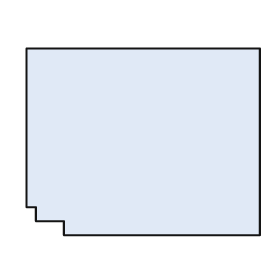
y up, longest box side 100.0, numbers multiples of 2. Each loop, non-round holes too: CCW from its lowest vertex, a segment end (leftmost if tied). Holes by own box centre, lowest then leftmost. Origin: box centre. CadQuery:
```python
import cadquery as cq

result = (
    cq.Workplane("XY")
    .moveTo(-34.0, -40.0)
    .lineTo(50.0, -40.0)
    .lineTo(50.0, 40.0)
    .lineTo(-50.0, 40.0)
    .lineTo(-50.0, -28.0)
    .lineTo(-46.0, -28.0)
    .lineTo(-46.0, -34.0)
    .lineTo(-34.0, -34.0)
    .close()
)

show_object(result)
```